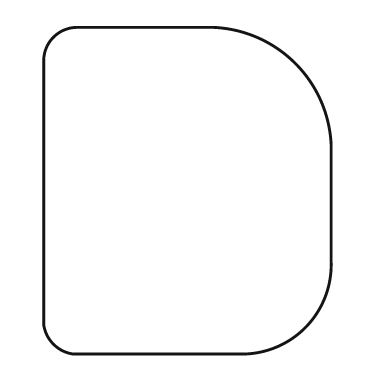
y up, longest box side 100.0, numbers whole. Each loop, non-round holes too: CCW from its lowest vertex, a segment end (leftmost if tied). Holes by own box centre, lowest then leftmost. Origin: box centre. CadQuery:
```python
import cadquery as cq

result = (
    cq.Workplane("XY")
    .moveTo(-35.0, -50.0)
    .lineTo(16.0, -50.0)
    .threePointArc((36.0, -42.0), (44.0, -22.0))
    .lineTo(44.0, 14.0)
    .threePointArc((33.0, 39.0), (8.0, 50.0))
    .lineTo(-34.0, 50.0)
    .threePointArc((-41.0, 47.0), (-44.0, 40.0))
    .lineTo(-44.0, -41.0)
    .threePointArc((-41.0, -47.0), (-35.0, -50.0))
    .close()
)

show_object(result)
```